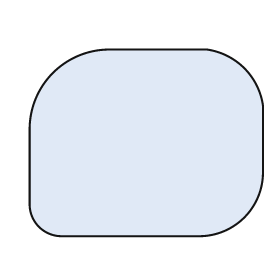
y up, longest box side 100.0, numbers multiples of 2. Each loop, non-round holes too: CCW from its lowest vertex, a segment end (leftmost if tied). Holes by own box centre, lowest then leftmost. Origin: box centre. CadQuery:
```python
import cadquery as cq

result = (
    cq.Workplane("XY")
    .moveTo(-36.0, -40.0)
    .lineTo(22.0, -40.0)
    .threePointArc((42.0, -32.0), (50.0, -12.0))
    .lineTo(50.0, 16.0)
    .threePointArc((42.0, 32.0), (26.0, 40.0))
    .lineTo(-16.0, 40.0)
    .threePointArc((-40.0, 30.0), (-50.0, 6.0))
    .lineTo(-50.0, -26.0)
    .threePointArc((-46.0, -36.0), (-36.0, -40.0))
    .close()
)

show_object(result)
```